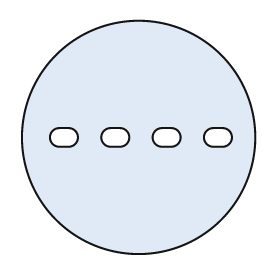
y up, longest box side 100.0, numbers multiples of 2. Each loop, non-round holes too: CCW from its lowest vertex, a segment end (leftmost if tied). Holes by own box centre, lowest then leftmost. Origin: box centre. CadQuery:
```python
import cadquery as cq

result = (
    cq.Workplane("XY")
    .moveTo(0.0, 0.0)
    .circle(50.0)
    .moveTo(-34.0, -4.0)
    .lineTo(-30.0, -4.0)
    .threePointArc((-26.0, 0.0), (-30.0, 4.0))
    .lineTo(-34.0, 4.0)
    .threePointArc((-38.0, 0.0), (-34.0, -4.0))
    .close()
    .moveTo(-12.0, -4.0)
    .lineTo(-8.0, -4.0)
    .threePointArc((-4.0, 0.0), (-8.0, 4.0))
    .lineTo(-12.0, 4.0)
    .threePointArc((-16.0, 0.0), (-12.0, -4.0))
    .close()
    .moveTo(10.0, -4.0)
    .lineTo(14.0, -4.0)
    .threePointArc((18.0, 0.0), (14.0, 4.0))
    .lineTo(10.0, 4.0)
    .threePointArc((6.0, 0.0), (10.0, -4.0))
    .close()
    .moveTo(32.0, -4.0)
    .lineTo(36.0, -4.0)
    .threePointArc((40.0, 0.0), (36.0, 4.0))
    .lineTo(32.0, 4.0)
    .threePointArc((28.0, 0.0), (32.0, -4.0))
    .close()
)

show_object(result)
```